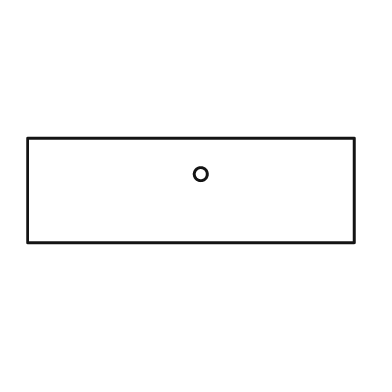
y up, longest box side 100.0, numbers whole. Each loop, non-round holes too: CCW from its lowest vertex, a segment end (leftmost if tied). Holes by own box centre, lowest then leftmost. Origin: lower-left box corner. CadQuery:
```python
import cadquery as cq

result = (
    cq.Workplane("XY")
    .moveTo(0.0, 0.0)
    .lineTo(100.0, 0.0)
    .lineTo(100.0, 32.0)
    .lineTo(0.0, 32.0)
    .close()
    .moveTo(53.0, 21.0)
    .circle(2.0)
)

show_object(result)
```